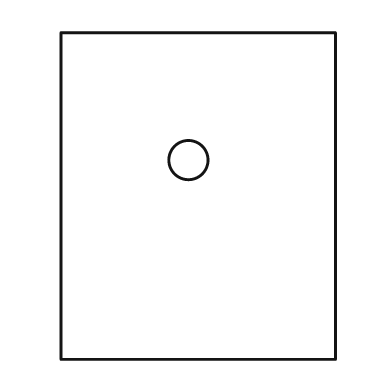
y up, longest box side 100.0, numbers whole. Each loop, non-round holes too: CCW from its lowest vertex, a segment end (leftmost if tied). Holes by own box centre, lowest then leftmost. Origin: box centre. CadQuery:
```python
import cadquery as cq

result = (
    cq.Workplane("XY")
    .moveTo(-42.0, -50.0)
    .lineTo(42.0, -50.0)
    .lineTo(42.0, 50.0)
    .lineTo(-42.0, 50.0)
    .close()
    .moveTo(-3.0, 11.0)
    .circle(6.0)
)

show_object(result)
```